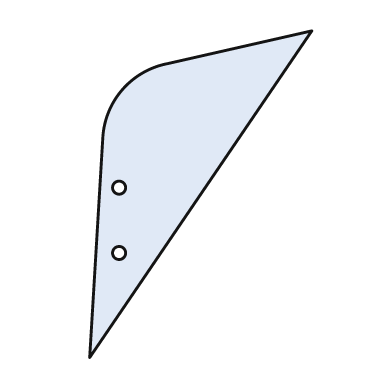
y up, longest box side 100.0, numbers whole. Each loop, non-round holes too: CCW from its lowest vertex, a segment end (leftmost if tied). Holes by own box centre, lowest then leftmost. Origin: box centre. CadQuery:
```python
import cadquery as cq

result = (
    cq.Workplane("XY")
    .moveTo(-34.0, -50.0)
    .lineTo(34.0, 50.0)
    .lineTo(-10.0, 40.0)
    .threePointArc((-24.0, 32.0), (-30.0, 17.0))
    .close()
    .moveTo(-25.0, -18.0)
    .circle(2.0)
    .moveTo(-25.0, 2.0)
    .circle(2.0)
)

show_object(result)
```